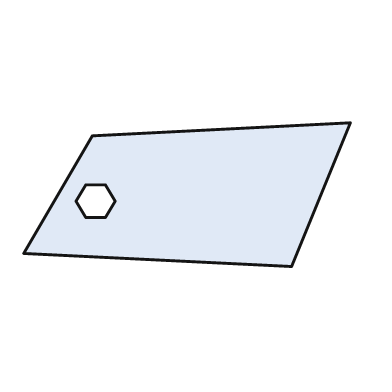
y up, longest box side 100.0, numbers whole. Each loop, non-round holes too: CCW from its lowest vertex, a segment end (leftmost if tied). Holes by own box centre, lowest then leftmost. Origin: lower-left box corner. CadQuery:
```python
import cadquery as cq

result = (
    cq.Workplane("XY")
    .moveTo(82.0, 0.0)
    .lineTo(100.0, 44.0)
    .lineTo(21.0, 40.0)
    .lineTo(0.0, 4.0)
    .close()
    .moveTo(19.0, 15.0)
    .lineTo(25.0, 15.0)
    .lineTo(28.0, 20.0)
    .lineTo(25.0, 25.0)
    .lineTo(19.0, 25.0)
    .lineTo(16.0, 20.0)
    .close()
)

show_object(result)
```